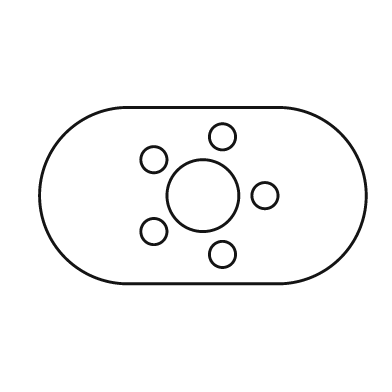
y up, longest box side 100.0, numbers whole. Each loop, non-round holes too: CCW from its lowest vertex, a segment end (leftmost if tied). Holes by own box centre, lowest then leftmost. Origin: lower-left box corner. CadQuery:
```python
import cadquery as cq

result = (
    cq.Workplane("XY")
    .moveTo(27.0, 0.0)
    .lineTo(73.0, 0.0)
    .threePointArc((100.0, 27.0), (73.0, 54.0))
    .lineTo(27.0, 54.0)
    .threePointArc((0.0, 27.0), (27.0, 0.0))
    .close()
    .moveTo(56.0, 9.0)
    .circle(4.0)
    .moveTo(35.0, 16.0)
    .circle(4.0)
    .moveTo(50.0, 27.0)
    .circle(11.0)
    .moveTo(69.0, 27.0)
    .circle(4.0)
    .moveTo(35.0, 38.0)
    .circle(4.0)
    .moveTo(56.0, 45.0)
    .circle(4.0)
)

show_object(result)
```